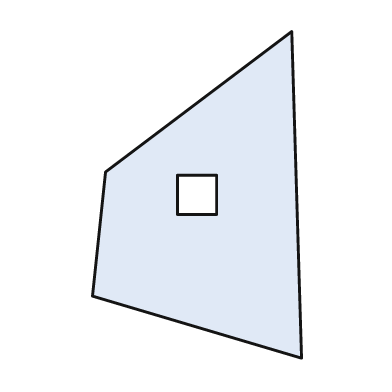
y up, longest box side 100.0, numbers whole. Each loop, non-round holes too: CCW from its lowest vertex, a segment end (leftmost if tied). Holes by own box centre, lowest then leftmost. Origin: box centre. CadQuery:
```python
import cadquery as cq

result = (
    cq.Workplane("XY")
    .moveTo(32.0, -50.0)
    .lineTo(29.0, 50.0)
    .lineTo(-28.0, 7.0)
    .lineTo(-32.0, -31.0)
    .close()
    .moveTo(-6.0, -6.0)
    .lineTo(6.0, -6.0)
    .lineTo(6.0, 6.0)
    .lineTo(-6.0, 6.0)
    .close()
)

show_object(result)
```